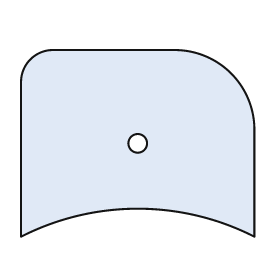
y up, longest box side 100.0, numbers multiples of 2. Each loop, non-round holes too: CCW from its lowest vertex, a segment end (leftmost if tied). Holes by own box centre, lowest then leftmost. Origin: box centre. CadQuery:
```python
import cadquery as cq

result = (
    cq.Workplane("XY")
    .moveTo(-50.0, -40.0)
    .threePointArc((0.0, -28.0), (50.0, -40.0))
    .lineTo(50.0, 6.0)
    .threePointArc((40.0, 30.0), (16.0, 40.0))
    .lineTo(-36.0, 40.0)
    .threePointArc((-46.0, 36.0), (-50.0, 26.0))
    .close()
    .moveTo(0.0, 0.0)
    .circle(4.0)
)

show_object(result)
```